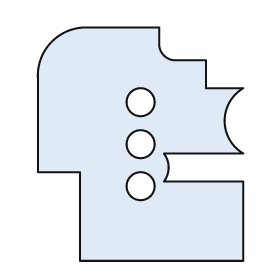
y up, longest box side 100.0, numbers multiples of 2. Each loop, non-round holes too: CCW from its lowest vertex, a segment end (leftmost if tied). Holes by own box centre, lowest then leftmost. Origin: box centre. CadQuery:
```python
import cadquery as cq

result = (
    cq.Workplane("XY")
    .moveTo(-26.0, -50.0)
    .lineTo(44.0, -50.0)
    .lineTo(44.0, -16.0)
    .lineTo(10.0, -16.0)
    .threePointArc((12.0, -10.0), (10.0, -4.0))
    .lineTo(44.0, -4.0)
    .threePointArc((36.0, 10.0), (44.0, 24.0))
    .lineTo(28.0, 24.0)
    .lineTo(28.0, 36.0)
    .lineTo(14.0, 36.0)
    .threePointArc((10.0, 38.0), (8.0, 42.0))
    .lineTo(8.0, 50.0)
    .lineTo(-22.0, 50.0)
    .threePointArc((-38.0, 44.0), (-44.0, 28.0))
    .lineTo(-44.0, -12.0)
    .lineTo(-26.0, -12.0)
    .close()
    .moveTo(0.0, -18.0)
    .circle(6.0)
    .moveTo(0.0, 0.0)
    .circle(6.0)
    .moveTo(0.0, 18.0)
    .circle(6.0)
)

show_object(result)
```